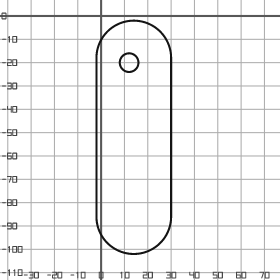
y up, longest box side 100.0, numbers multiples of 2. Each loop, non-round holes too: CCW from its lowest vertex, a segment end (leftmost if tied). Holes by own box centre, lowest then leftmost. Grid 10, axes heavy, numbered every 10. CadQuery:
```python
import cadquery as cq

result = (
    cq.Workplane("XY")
    .moveTo(-2.0, -86.0)
    .threePointArc((14.0, -102.0), (30.0, -86.0))
    .lineTo(30.0, -18.0)
    .threePointArc((14.0, -2.0), (-2.0, -18.0))
    .close()
    .moveTo(12.0, -20.0)
    .circle(4.0)
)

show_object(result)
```